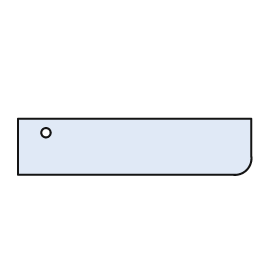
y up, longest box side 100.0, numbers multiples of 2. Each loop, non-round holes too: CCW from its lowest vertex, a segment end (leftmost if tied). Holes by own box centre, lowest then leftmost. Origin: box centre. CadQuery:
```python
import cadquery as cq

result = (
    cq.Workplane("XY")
    .moveTo(-50.0, -12.0)
    .lineTo(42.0, -12.0)
    .threePointArc((48.0, -10.0), (50.0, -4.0))
    .lineTo(50.0, 12.0)
    .lineTo(-50.0, 12.0)
    .close()
    .moveTo(-38.0, 6.0)
    .circle(2.0)
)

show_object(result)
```